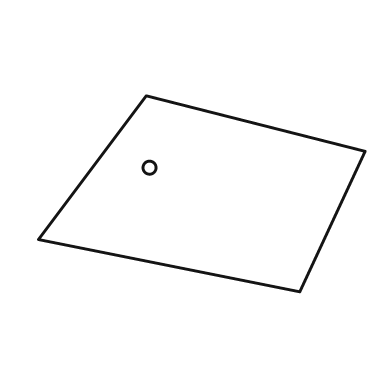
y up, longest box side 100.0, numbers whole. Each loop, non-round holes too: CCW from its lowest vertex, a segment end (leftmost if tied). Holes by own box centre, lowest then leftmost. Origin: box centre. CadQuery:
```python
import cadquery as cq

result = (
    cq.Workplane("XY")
    .moveTo(30.0, -30.0)
    .lineTo(50.0, 13.0)
    .lineTo(-17.0, 30.0)
    .lineTo(-50.0, -14.0)
    .close()
    .moveTo(-16.0, 8.0)
    .circle(2.0)
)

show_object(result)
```